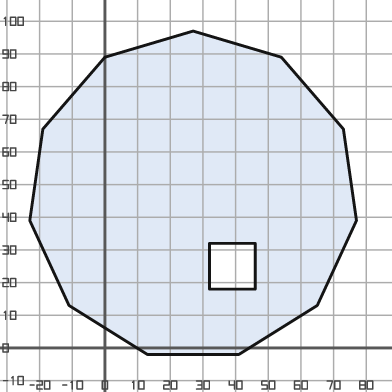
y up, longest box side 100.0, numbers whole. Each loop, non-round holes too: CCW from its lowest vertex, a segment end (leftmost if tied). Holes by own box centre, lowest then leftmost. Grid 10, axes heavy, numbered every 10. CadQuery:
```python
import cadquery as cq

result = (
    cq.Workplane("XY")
    .moveTo(13.0, -2.0)
    .lineTo(41.0, -2.0)
    .lineTo(65.0, 13.0)
    .lineTo(77.0, 39.0)
    .lineTo(73.0, 67.0)
    .lineTo(54.0, 89.0)
    .lineTo(27.0, 97.0)
    .lineTo(0.0, 89.0)
    .lineTo(-19.0, 67.0)
    .lineTo(-23.0, 39.0)
    .lineTo(-11.0, 13.0)
    .close()
    .moveTo(32.0, 18.0)
    .lineTo(46.0, 18.0)
    .lineTo(46.0, 32.0)
    .lineTo(32.0, 32.0)
    .close()
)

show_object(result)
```